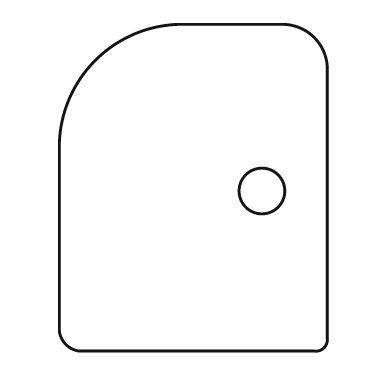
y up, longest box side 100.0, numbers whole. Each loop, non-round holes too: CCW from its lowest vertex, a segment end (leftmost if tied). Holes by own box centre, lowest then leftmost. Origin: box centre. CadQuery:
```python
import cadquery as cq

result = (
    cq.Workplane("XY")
    .moveTo(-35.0, -50.0)
    .lineTo(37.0, -50.0)
    .threePointArc((40.0, -49.0), (41.0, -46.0))
    .lineTo(41.0, 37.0)
    .threePointArc((37.0, 46.0), (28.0, 50.0))
    .lineTo(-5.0, 50.0)
    .threePointArc((-30.0, 39.0), (-41.0, 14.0))
    .lineTo(-41.0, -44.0)
    .threePointArc((-39.0, -48.0), (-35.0, -50.0))
    .close()
    .moveTo(21.0, -1.0)
    .circle(7.0)
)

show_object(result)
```